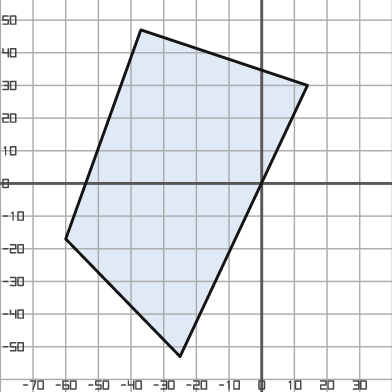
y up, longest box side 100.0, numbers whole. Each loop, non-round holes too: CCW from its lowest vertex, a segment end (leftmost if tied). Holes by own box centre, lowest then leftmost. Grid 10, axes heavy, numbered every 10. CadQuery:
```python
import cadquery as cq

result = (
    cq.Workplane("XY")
    .moveTo(-25.0, -53.0)
    .lineTo(14.0, 30.0)
    .lineTo(-37.0, 47.0)
    .lineTo(-60.0, -17.0)
    .close()
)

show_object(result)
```